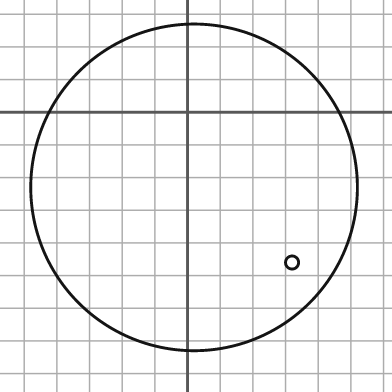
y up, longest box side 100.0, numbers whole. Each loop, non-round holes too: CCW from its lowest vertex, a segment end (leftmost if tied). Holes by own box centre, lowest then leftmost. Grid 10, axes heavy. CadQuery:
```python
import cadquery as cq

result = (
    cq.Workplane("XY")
    .moveTo(2.0, -23.0)
    .circle(50.0)
    .moveTo(32.0, -46.0)
    .circle(2.0)
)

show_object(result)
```